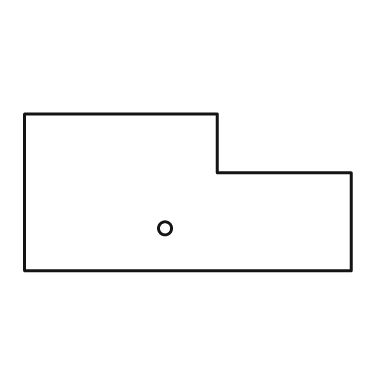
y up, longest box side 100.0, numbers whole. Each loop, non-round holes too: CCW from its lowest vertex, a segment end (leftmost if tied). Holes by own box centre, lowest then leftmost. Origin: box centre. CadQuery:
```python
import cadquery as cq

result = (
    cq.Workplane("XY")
    .moveTo(-50.0, -24.0)
    .lineTo(50.0, -24.0)
    .lineTo(50.0, 6.0)
    .lineTo(9.0, 6.0)
    .lineTo(9.0, 24.0)
    .lineTo(-50.0, 24.0)
    .close()
    .moveTo(-7.0, -11.0)
    .circle(2.0)
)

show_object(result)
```